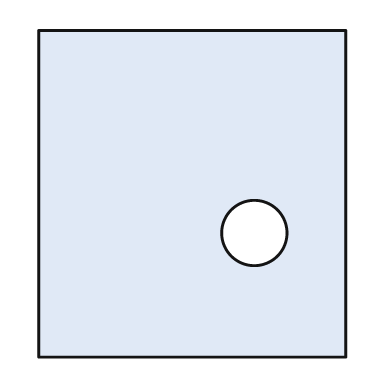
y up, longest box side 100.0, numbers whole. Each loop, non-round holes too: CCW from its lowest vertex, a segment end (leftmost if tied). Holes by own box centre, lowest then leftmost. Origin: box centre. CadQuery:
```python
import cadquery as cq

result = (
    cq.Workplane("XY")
    .moveTo(-47.0, -50.0)
    .lineTo(47.0, -50.0)
    .lineTo(47.0, 50.0)
    .lineTo(-47.0, 50.0)
    .close()
    .moveTo(19.0, -12.0)
    .circle(10.0)
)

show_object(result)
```